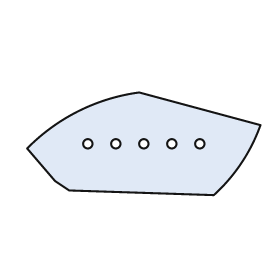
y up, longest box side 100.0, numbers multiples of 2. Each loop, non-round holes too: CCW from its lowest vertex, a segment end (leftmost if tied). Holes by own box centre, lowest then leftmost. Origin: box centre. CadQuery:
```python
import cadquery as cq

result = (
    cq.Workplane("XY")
    .moveTo(30.0, -22.0)
    .threePointArc((42.0, -8.0), (50.0, 8.0))
    .lineTo(-2.0, 22.0)
    .threePointArc((-28.0, 14.0), (-50.0, -2.0))
    .lineTo(-38.0, -16.0)
    .lineTo(-32.0, -20.0)
    .close()
    .moveTo(-24.0, 0.0)
    .circle(2.0)
    .moveTo(-12.0, 0.0)
    .circle(2.0)
    .moveTo(0.0, 0.0)
    .circle(2.0)
    .moveTo(12.0, 0.0)
    .circle(2.0)
    .moveTo(24.0, 0.0)
    .circle(2.0)
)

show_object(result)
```